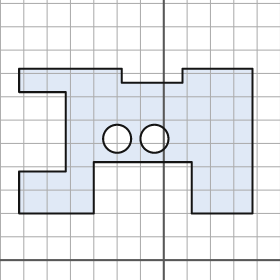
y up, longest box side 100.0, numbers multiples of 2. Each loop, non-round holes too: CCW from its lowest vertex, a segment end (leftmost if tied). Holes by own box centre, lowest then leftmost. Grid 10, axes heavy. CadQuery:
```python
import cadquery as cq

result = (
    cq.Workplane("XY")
    .moveTo(-62.0, 20.0)
    .lineTo(-30.0, 20.0)
    .lineTo(-30.0, 42.0)
    .lineTo(12.0, 42.0)
    .lineTo(12.0, 20.0)
    .lineTo(38.0, 20.0)
    .lineTo(38.0, 82.0)
    .lineTo(8.0, 82.0)
    .lineTo(8.0, 76.0)
    .lineTo(-18.0, 76.0)
    .lineTo(-18.0, 82.0)
    .lineTo(-62.0, 82.0)
    .lineTo(-62.0, 72.0)
    .lineTo(-42.0, 72.0)
    .lineTo(-42.0, 38.0)
    .lineTo(-62.0, 38.0)
    .close()
    .moveTo(-20.0, 52.0)
    .circle(6.0)
    .moveTo(-4.0, 52.0)
    .circle(6.0)
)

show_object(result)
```